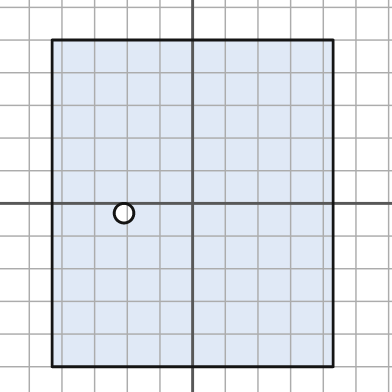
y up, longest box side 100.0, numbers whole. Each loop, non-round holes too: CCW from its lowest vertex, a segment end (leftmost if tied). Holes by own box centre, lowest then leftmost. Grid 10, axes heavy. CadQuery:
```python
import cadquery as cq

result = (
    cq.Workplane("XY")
    .moveTo(-43.0, -50.0)
    .lineTo(43.0, -50.0)
    .lineTo(43.0, 50.0)
    .lineTo(-43.0, 50.0)
    .close()
    .moveTo(-21.0, -3.0)
    .circle(3.0)
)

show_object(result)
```